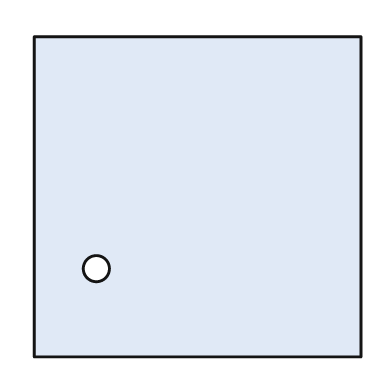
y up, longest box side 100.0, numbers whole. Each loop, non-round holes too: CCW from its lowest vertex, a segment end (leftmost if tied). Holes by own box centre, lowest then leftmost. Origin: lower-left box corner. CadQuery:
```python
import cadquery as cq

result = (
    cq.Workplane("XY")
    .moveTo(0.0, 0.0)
    .lineTo(100.0, 0.0)
    .lineTo(100.0, 98.0)
    .lineTo(0.0, 98.0)
    .close()
    .moveTo(19.0, 27.0)
    .circle(4.0)
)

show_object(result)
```